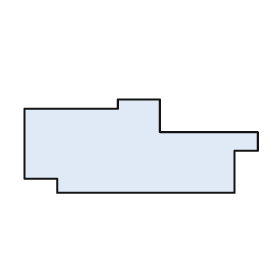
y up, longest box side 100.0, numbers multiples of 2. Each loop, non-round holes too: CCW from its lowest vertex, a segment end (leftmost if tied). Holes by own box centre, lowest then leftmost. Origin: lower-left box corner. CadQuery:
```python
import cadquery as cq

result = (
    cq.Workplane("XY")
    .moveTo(14.0, 0.0)
    .lineTo(90.0, 0.0)
    .lineTo(90.0, 18.0)
    .lineTo(100.0, 18.0)
    .lineTo(100.0, 26.0)
    .lineTo(58.0, 26.0)
    .lineTo(58.0, 40.0)
    .lineTo(40.0, 40.0)
    .lineTo(40.0, 36.0)
    .lineTo(0.0, 36.0)
    .lineTo(0.0, 6.0)
    .lineTo(14.0, 6.0)
    .close()
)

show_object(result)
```